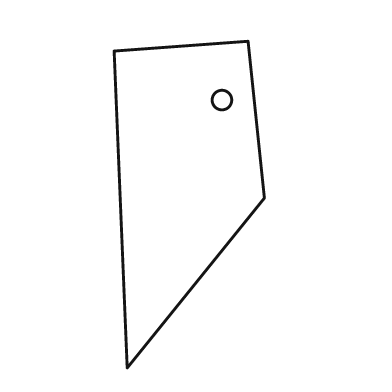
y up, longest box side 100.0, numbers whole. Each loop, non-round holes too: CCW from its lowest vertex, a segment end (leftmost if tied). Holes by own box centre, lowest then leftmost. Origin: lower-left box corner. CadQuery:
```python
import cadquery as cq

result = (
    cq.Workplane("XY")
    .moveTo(4.0, 0.0)
    .lineTo(46.0, 52.0)
    .lineTo(41.0, 100.0)
    .lineTo(0.0, 97.0)
    .close()
    .moveTo(33.0, 82.0)
    .circle(3.0)
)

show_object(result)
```